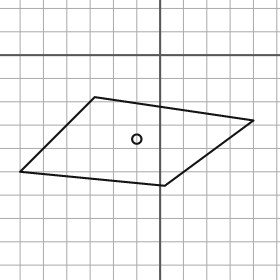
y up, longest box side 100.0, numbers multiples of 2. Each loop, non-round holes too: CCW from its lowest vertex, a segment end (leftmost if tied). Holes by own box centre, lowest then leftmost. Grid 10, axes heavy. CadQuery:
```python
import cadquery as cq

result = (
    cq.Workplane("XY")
    .moveTo(2.0, -56.0)
    .lineTo(40.0, -28.0)
    .lineTo(-28.0, -18.0)
    .lineTo(-60.0, -50.0)
    .close()
    .moveTo(-10.0, -36.0)
    .circle(2.0)
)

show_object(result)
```